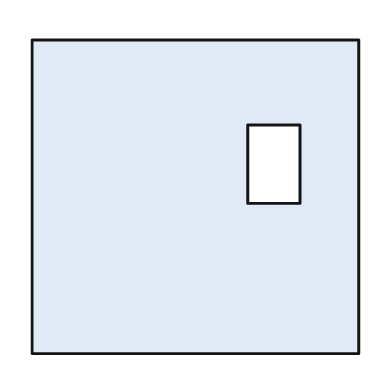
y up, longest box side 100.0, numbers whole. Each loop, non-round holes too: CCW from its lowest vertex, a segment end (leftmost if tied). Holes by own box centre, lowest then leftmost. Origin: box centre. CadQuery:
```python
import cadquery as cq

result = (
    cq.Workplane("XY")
    .moveTo(-50.0, -48.0)
    .lineTo(50.0, -48.0)
    .lineTo(50.0, 48.0)
    .lineTo(-50.0, 48.0)
    .close()
    .moveTo(16.0, -2.0)
    .lineTo(32.0, -2.0)
    .lineTo(32.0, 22.0)
    .lineTo(16.0, 22.0)
    .close()
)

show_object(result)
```